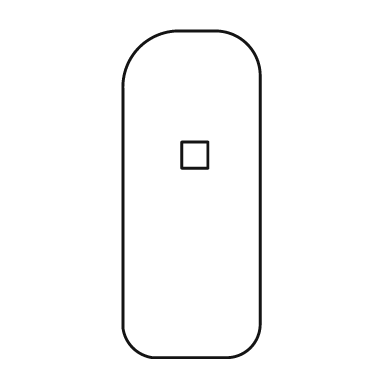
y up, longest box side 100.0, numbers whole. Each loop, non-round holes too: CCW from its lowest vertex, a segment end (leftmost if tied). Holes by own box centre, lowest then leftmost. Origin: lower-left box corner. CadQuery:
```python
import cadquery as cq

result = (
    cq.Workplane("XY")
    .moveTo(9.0, 0.0)
    .lineTo(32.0, 0.0)
    .threePointArc((39.0, 3.0), (42.0, 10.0))
    .lineTo(42.0, 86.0)
    .threePointArc((38.0, 96.0), (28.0, 100.0))
    .lineTo(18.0, 100.0)
    .threePointArc((5.0, 95.0), (0.0, 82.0))
    .lineTo(0.0, 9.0)
    .threePointArc((3.0, 3.0), (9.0, 0.0))
    .close()
    .moveTo(18.0, 58.0)
    .lineTo(26.0, 58.0)
    .lineTo(26.0, 66.0)
    .lineTo(18.0, 66.0)
    .close()
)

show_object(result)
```